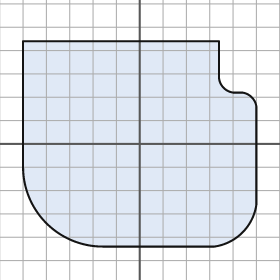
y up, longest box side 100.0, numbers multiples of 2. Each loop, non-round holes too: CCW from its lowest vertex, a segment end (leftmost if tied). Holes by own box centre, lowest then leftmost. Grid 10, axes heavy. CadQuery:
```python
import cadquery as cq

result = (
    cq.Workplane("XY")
    .moveTo(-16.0, -44.0)
    .lineTo(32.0, -44.0)
    .threePointArc((44.0, -38.0), (50.0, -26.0))
    .lineTo(50.0, 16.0)
    .threePointArc((48.0, 20.0), (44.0, 22.0))
    .lineTo(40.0, 22.0)
    .threePointArc((36.0, 24.0), (34.0, 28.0))
    .lineTo(34.0, 44.0)
    .lineTo(-50.0, 44.0)
    .lineTo(-50.0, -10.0)
    .threePointArc((-40.0, -34.0), (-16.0, -44.0))
    .close()
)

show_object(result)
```